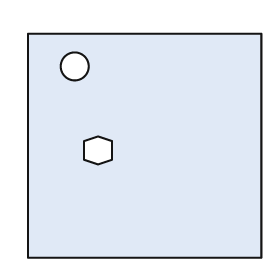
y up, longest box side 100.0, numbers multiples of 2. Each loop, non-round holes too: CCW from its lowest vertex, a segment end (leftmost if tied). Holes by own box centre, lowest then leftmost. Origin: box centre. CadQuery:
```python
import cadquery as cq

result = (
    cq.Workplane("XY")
    .moveTo(-50.0, -48.0)
    .lineTo(50.0, -48.0)
    .lineTo(50.0, 48.0)
    .lineTo(-50.0, 48.0)
    .close()
    .moveTo(-20.0, -8.0)
    .lineTo(-14.0, -6.0)
    .lineTo(-14.0, 2.0)
    .lineTo(-20.0, 4.0)
    .lineTo(-26.0, 2.0)
    .lineTo(-26.0, -6.0)
    .close()
    .moveTo(-30.0, 34.0)
    .circle(6.0)
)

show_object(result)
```